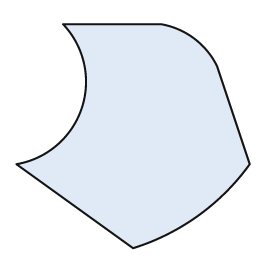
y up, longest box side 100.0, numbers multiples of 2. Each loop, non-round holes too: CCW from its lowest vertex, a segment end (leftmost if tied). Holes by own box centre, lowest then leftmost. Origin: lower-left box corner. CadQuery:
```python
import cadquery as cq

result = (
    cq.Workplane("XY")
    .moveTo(50.0, 0.0)
    .threePointArc((78.0, 14.0), (100.0, 36.0))
    .lineTo(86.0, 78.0)
    .threePointArc((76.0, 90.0), (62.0, 96.0))
    .lineTo(20.0, 96.0)
    .threePointArc((28.0, 60.0), (0.0, 36.0))
    .close()
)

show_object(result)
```